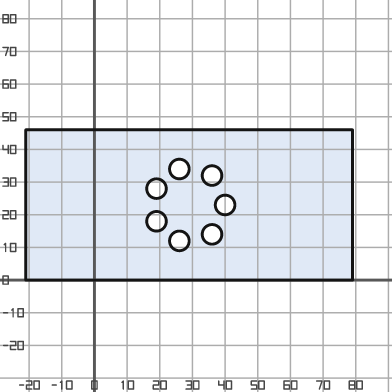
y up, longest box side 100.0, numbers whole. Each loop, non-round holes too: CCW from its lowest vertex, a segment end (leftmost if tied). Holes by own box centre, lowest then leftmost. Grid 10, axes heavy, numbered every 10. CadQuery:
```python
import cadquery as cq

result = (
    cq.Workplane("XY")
    .moveTo(-21.0, 0.0)
    .lineTo(79.0, 0.0)
    .lineTo(79.0, 46.0)
    .lineTo(-21.0, 46.0)
    .close()
    .moveTo(26.0, 12.0)
    .circle(3.0)
    .moveTo(36.0, 14.0)
    .circle(3.0)
    .moveTo(19.0, 18.0)
    .circle(3.0)
    .moveTo(40.0, 23.0)
    .circle(3.0)
    .moveTo(19.0, 28.0)
    .circle(3.0)
    .moveTo(36.0, 32.0)
    .circle(3.0)
    .moveTo(26.0, 34.0)
    .circle(3.0)
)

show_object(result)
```